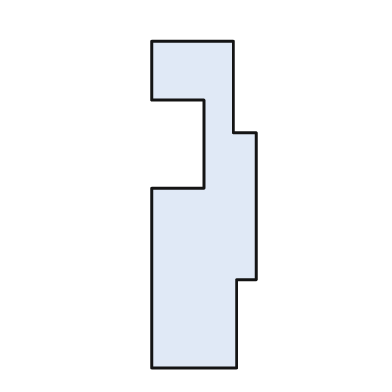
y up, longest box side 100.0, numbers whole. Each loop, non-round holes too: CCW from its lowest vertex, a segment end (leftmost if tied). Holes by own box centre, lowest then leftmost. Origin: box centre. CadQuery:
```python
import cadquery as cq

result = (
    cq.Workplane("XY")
    .moveTo(-16.0, -50.0)
    .lineTo(10.0, -50.0)
    .lineTo(10.0, -23.0)
    .lineTo(16.0, -23.0)
    .lineTo(16.0, 22.0)
    .lineTo(9.0, 22.0)
    .lineTo(9.0, 50.0)
    .lineTo(-16.0, 50.0)
    .lineTo(-16.0, 32.0)
    .lineTo(0.0, 32.0)
    .lineTo(0.0, 5.0)
    .lineTo(-16.0, 5.0)
    .close()
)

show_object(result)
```